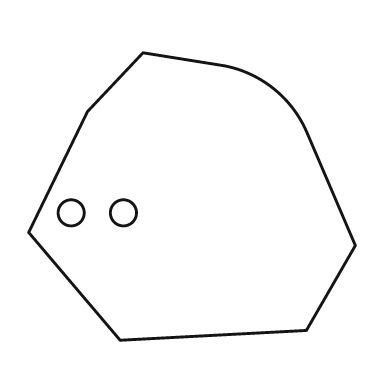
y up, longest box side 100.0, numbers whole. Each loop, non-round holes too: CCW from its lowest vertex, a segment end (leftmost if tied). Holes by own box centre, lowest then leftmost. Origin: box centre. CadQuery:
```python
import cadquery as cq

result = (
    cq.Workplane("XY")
    .moveTo(-22.0, -44.0)
    .lineTo(35.0, -41.0)
    .lineTo(50.0, -15.0)
    .lineTo(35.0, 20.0)
    .threePointArc((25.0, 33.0), (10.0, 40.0))
    .lineTo(-15.0, 44.0)
    .lineTo(-32.0, 26.0)
    .lineTo(-50.0, -11.0)
    .close()
    .moveTo(-37.0, -5.0)
    .circle(4.0)
    .moveTo(-21.0, -5.0)
    .circle(4.0)
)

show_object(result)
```